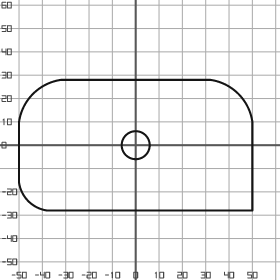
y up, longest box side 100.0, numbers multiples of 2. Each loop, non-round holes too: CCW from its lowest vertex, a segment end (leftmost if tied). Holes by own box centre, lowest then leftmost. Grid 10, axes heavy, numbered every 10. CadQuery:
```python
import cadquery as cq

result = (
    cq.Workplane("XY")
    .moveTo(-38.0, -28.0)
    .lineTo(50.0, -28.0)
    .lineTo(50.0, 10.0)
    .threePointArc((44.0, 22.0), (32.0, 28.0))
    .lineTo(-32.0, 28.0)
    .threePointArc((-44.0, 22.0), (-50.0, 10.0))
    .lineTo(-50.0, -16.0)
    .threePointArc((-46.0, -24.0), (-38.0, -28.0))
    .close()
    .moveTo(0.0, 0.0)
    .circle(6.0)
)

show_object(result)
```